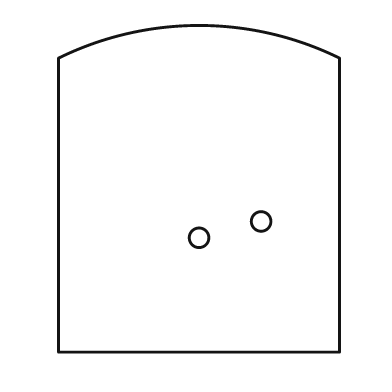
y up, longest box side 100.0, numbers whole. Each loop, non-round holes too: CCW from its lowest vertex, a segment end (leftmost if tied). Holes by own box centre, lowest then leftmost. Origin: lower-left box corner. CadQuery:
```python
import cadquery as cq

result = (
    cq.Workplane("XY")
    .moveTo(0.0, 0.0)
    .lineTo(86.0, 0.0)
    .lineTo(86.0, 90.0)
    .threePointArc((43.0, 100.0), (0.0, 90.0))
    .close()
    .moveTo(43.0, 35.0)
    .circle(3.0)
    .moveTo(62.0, 40.0)
    .circle(3.0)
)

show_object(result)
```